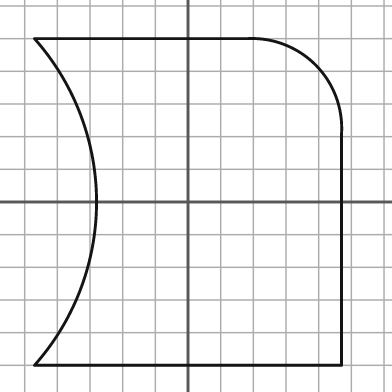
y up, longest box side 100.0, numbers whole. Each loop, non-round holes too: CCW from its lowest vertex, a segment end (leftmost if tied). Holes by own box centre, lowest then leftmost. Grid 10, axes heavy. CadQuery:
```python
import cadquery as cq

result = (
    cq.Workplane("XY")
    .moveTo(-47.0, -50.0)
    .lineTo(47.0, -50.0)
    .lineTo(47.0, 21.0)
    .threePointArc((39.0, 42.0), (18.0, 50.0))
    .lineTo(-47.0, 50.0)
    .threePointArc((-28.0, 0.0), (-47.0, -50.0))
    .close()
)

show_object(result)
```